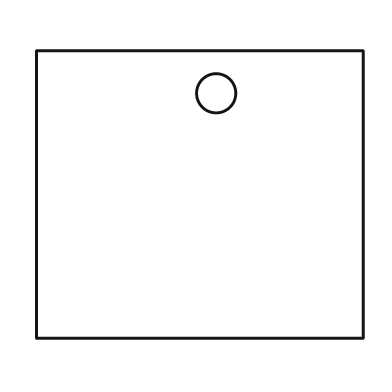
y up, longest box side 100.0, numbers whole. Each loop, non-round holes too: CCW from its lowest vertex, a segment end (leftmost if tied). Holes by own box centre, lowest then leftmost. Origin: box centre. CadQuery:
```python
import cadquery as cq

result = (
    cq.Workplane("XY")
    .moveTo(-50.0, -44.0)
    .lineTo(50.0, -44.0)
    .lineTo(50.0, 44.0)
    .lineTo(-50.0, 44.0)
    .close()
    .moveTo(5.0, 31.0)
    .circle(6.0)
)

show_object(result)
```